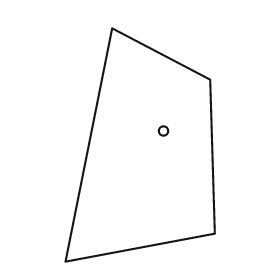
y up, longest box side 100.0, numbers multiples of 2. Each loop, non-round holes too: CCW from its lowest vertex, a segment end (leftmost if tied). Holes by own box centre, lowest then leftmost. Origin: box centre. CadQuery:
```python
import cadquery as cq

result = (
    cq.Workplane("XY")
    .moveTo(-32.0, -50.0)
    .lineTo(32.0, -38.0)
    .lineTo(30.0, 28.0)
    .lineTo(-12.0, 50.0)
    .close()
    .moveTo(10.0, 6.0)
    .circle(2.0)
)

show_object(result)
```